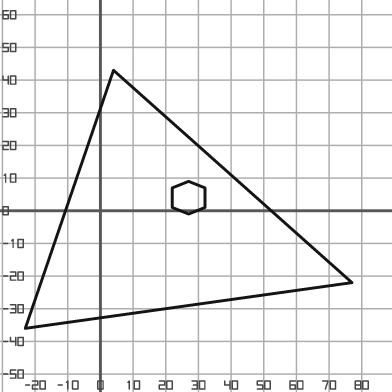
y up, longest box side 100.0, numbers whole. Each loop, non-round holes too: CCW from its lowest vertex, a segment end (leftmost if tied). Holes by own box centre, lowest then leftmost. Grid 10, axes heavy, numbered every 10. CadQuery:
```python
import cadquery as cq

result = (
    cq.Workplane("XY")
    .moveTo(-23.0, -36.0)
    .lineTo(77.0, -22.0)
    .lineTo(4.0, 43.0)
    .close()
    .moveTo(27.0, -1.0)
    .lineTo(32.0, 1.0)
    .lineTo(32.0, 7.0)
    .lineTo(27.0, 9.0)
    .lineTo(22.0, 7.0)
    .lineTo(22.0, 1.0)
    .close()
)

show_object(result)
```